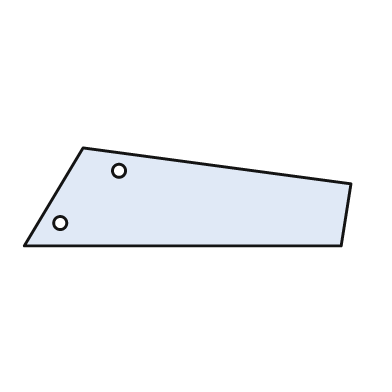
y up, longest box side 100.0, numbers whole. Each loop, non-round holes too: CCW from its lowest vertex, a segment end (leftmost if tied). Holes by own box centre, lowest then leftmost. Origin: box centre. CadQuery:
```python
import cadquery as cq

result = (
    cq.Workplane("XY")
    .moveTo(-50.0, -15.0)
    .lineTo(47.0, -15.0)
    .lineTo(50.0, 4.0)
    .lineTo(-32.0, 15.0)
    .close()
    .moveTo(-39.0, -8.0)
    .circle(2.0)
    .moveTo(-21.0, 8.0)
    .circle(2.0)
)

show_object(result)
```